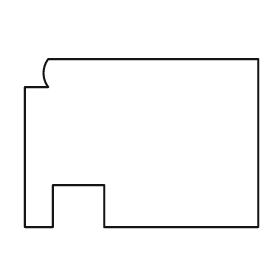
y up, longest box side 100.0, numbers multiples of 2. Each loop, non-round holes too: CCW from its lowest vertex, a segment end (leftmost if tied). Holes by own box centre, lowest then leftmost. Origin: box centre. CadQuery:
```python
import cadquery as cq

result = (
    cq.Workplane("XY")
    .moveTo(-50.0, -36.0)
    .lineTo(-38.0, -36.0)
    .lineTo(-38.0, -18.0)
    .lineTo(-16.0, -18.0)
    .lineTo(-16.0, -36.0)
    .lineTo(50.0, -36.0)
    .lineTo(50.0, 36.0)
    .lineTo(-40.0, 36.0)
    .threePointArc((-42.0, 30.0), (-40.0, 24.0))
    .lineTo(-50.0, 24.0)
    .close()
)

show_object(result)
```